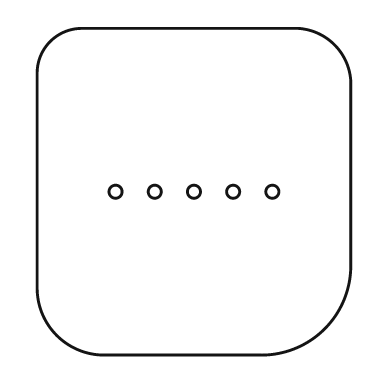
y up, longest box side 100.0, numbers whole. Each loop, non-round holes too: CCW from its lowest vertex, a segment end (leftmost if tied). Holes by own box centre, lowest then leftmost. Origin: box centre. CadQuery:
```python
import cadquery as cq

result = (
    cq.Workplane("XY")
    .moveTo(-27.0, -50.0)
    .lineTo(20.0, -50.0)
    .threePointArc((40.0, -42.0), (48.0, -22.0))
    .lineTo(48.0, 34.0)
    .threePointArc((43.0, 45.0), (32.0, 50.0))
    .lineTo(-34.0, 50.0)
    .threePointArc((-44.0, 46.0), (-48.0, 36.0))
    .lineTo(-48.0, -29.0)
    .threePointArc((-42.0, -44.0), (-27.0, -50.0))
    .close()
    .moveTo(-24.0, 0.0)
    .circle(2.0)
    .moveTo(-12.0, 0.0)
    .circle(2.0)
    .moveTo(0.0, 0.0)
    .circle(2.0)
    .moveTo(12.0, 0.0)
    .circle(2.0)
    .moveTo(24.0, 0.0)
    .circle(2.0)
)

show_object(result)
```